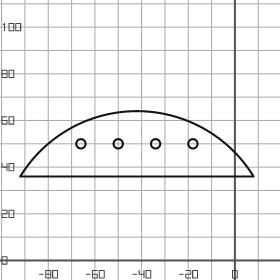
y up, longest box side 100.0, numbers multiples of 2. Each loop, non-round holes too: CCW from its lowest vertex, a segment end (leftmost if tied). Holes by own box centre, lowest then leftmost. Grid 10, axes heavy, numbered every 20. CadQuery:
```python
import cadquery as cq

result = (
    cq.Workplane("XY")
    .moveTo(-92.0, 36.0)
    .lineTo(8.0, 36.0)
    .threePointArc((-42.0, 64.0), (-92.0, 36.0))
    .close()
    .moveTo(-66.0, 50.0)
    .circle(2.0)
    .moveTo(-50.0, 50.0)
    .circle(2.0)
    .moveTo(-34.0, 50.0)
    .circle(2.0)
    .moveTo(-18.0, 50.0)
    .circle(2.0)
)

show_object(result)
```